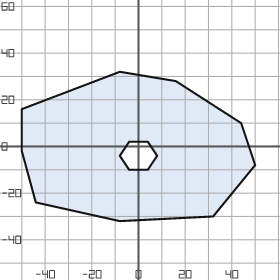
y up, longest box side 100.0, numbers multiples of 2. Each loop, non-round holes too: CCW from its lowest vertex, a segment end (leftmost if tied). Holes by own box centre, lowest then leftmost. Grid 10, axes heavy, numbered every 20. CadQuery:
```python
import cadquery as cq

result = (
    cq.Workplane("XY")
    .moveTo(-8.0, -32.0)
    .lineTo(32.0, -30.0)
    .lineTo(50.0, -8.0)
    .lineTo(44.0, 10.0)
    .lineTo(16.0, 28.0)
    .lineTo(-8.0, 32.0)
    .lineTo(-50.0, 16.0)
    .lineTo(-50.0, -2.0)
    .lineTo(-44.0, -24.0)
    .close()
    .moveTo(-4.0, -10.0)
    .lineTo(4.0, -10.0)
    .lineTo(8.0, -4.0)
    .lineTo(4.0, 2.0)
    .lineTo(-4.0, 2.0)
    .lineTo(-8.0, -4.0)
    .close()
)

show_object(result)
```